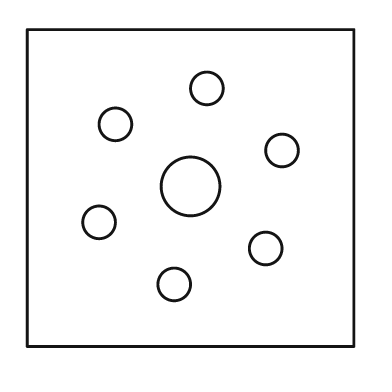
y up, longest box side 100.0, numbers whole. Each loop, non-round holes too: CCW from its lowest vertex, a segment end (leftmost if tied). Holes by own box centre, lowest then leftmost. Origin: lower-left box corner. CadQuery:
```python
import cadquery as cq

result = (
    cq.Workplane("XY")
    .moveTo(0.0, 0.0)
    .lineTo(100.0, 0.0)
    .lineTo(100.0, 97.0)
    .lineTo(0.0, 97.0)
    .close()
    .moveTo(45.0, 19.0)
    .circle(5.0)
    .moveTo(73.0, 30.0)
    .circle(5.0)
    .moveTo(22.0, 38.0)
    .circle(5.0)
    .moveTo(50.0, 49.0)
    .circle(9.0)
    .moveTo(78.0, 60.0)
    .circle(5.0)
    .moveTo(27.0, 68.0)
    .circle(5.0)
    .moveTo(55.0, 79.0)
    .circle(5.0)
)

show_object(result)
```